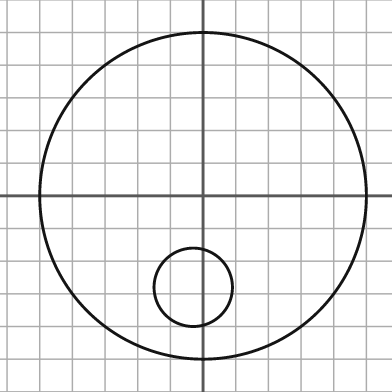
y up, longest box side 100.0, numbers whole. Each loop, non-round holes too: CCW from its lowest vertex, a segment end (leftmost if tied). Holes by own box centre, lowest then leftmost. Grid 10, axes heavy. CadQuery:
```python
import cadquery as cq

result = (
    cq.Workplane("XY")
    .moveTo(0.0, 0.0)
    .circle(50.0)
    .moveTo(-3.0, -28.0)
    .circle(12.0)
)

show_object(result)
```